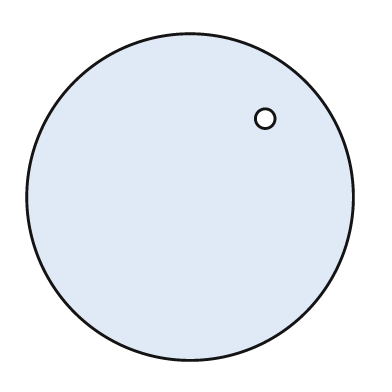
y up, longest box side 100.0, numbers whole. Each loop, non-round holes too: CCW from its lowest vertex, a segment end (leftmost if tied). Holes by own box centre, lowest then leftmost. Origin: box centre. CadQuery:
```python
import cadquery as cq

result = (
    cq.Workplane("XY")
    .moveTo(0.0, 0.0)
    .circle(50.0)
    .moveTo(23.0, 24.0)
    .circle(3.0)
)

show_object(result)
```